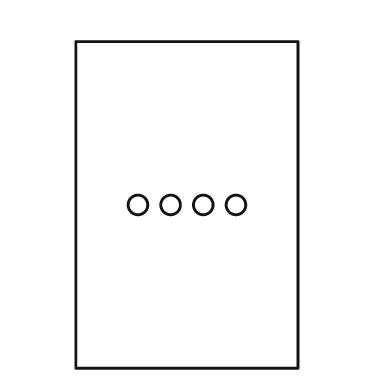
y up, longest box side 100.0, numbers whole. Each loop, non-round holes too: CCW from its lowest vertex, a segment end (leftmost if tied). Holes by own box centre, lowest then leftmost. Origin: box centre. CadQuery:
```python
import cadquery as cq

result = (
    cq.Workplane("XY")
    .moveTo(-34.0, -50.0)
    .lineTo(34.0, -50.0)
    .lineTo(34.0, 50.0)
    .lineTo(-34.0, 50.0)
    .close()
    .moveTo(-15.0, 0.0)
    .circle(3.0)
    .moveTo(-5.0, 0.0)
    .circle(3.0)
    .moveTo(5.0, 0.0)
    .circle(3.0)
    .moveTo(15.0, 0.0)
    .circle(3.0)
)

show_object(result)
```